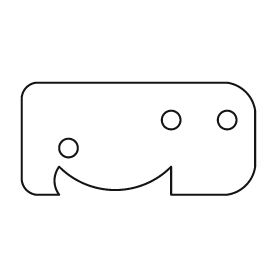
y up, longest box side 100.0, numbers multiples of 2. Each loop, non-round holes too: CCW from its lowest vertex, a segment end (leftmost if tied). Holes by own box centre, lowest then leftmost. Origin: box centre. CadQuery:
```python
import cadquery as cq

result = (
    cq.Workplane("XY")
    .moveTo(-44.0, -24.0)
    .lineTo(-34.0, -24.0)
    .threePointArc((-36.0, -18.0), (-34.0, -12.0))
    .threePointArc((-10.0, -22.0), (14.0, -12.0))
    .lineTo(14.0, -24.0)
    .lineTo(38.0, -24.0)
    .threePointArc((46.0, -20.0), (50.0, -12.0))
    .lineTo(50.0, 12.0)
    .threePointArc((46.0, 20.0), (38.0, 24.0))
    .lineTo(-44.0, 24.0)
    .threePointArc((-48.0, 22.0), (-50.0, 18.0))
    .lineTo(-50.0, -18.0)
    .threePointArc((-48.0, -22.0), (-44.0, -24.0))
    .close()
    .moveTo(-30.0, -4.0)
    .circle(4.0)
    .moveTo(14.0, 8.0)
    .circle(4.0)
    .moveTo(38.0, 8.0)
    .circle(4.0)
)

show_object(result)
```